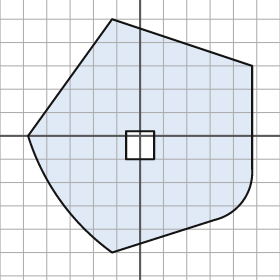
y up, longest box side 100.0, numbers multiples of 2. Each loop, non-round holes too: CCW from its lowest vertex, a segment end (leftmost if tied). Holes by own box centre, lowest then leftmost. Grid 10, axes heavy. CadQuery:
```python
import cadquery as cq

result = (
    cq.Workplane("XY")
    .moveTo(-12.0, -50.0)
    .lineTo(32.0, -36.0)
    .threePointArc((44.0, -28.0), (48.0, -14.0))
    .lineTo(48.0, 30.0)
    .lineTo(-12.0, 50.0)
    .lineTo(-48.0, 0.0)
    .threePointArc((-34.0, -28.0), (-12.0, -50.0))
    .close()
    .moveTo(-6.0, -10.0)
    .lineTo(6.0, -10.0)
    .lineTo(6.0, 2.0)
    .lineTo(-6.0, 2.0)
    .close()
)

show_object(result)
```